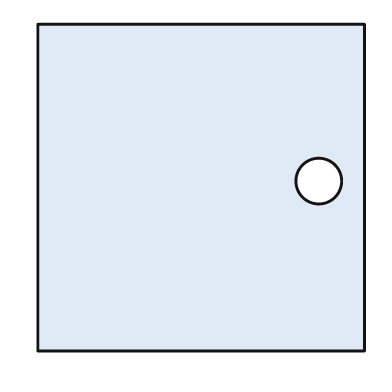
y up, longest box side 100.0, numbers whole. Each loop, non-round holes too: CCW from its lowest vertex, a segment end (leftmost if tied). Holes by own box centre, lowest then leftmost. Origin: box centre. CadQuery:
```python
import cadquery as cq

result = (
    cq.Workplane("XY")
    .moveTo(-50.0, -50.0)
    .lineTo(50.0, -50.0)
    .lineTo(50.0, 50.0)
    .lineTo(-50.0, 50.0)
    .close()
    .moveTo(36.0, 2.0)
    .circle(7.0)
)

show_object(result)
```